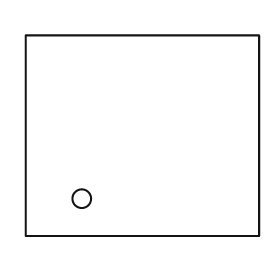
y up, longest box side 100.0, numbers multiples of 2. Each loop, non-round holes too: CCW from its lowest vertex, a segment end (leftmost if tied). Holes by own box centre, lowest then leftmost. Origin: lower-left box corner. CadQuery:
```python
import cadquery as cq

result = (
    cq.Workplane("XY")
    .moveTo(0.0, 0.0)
    .lineTo(100.0, 0.0)
    .lineTo(100.0, 86.0)
    .lineTo(0.0, 86.0)
    .close()
    .moveTo(24.0, 16.0)
    .circle(4.0)
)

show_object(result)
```